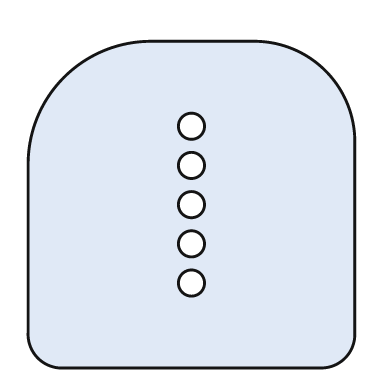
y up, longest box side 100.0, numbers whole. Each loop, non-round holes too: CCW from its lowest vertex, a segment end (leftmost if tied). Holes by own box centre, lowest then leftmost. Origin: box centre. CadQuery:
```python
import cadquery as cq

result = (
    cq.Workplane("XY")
    .moveTo(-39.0, -50.0)
    .lineTo(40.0, -50.0)
    .threePointArc((47.0, -47.0), (50.0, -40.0))
    .lineTo(50.0, 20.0)
    .threePointArc((41.0, 41.0), (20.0, 50.0))
    .lineTo(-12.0, 50.0)
    .threePointArc((-39.0, 39.0), (-50.0, 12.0))
    .lineTo(-50.0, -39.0)
    .threePointArc((-47.0, -47.0), (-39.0, -50.0))
    .close()
    .moveTo(0.0, -24.0)
    .circle(4.0)
    .moveTo(0.0, -12.0)
    .circle(4.0)
    .moveTo(0.0, 0.0)
    .circle(4.0)
    .moveTo(0.0, 12.0)
    .circle(4.0)
    .moveTo(0.0, 24.0)
    .circle(4.0)
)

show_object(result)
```